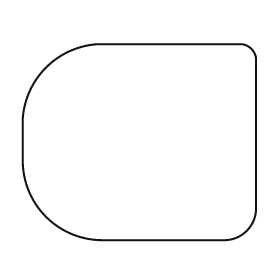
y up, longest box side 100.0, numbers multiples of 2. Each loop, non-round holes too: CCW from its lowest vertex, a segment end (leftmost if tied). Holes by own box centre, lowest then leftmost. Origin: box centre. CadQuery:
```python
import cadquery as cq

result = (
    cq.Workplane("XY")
    .moveTo(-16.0, -42.0)
    .lineTo(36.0, -42.0)
    .threePointArc((46.0, -38.0), (50.0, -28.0))
    .lineTo(50.0, 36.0)
    .threePointArc((48.0, 40.0), (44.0, 42.0))
    .lineTo(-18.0, 42.0)
    .threePointArc((-40.0, 32.0), (-50.0, 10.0))
    .lineTo(-50.0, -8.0)
    .threePointArc((-40.0, -32.0), (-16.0, -42.0))
    .close()
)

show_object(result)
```